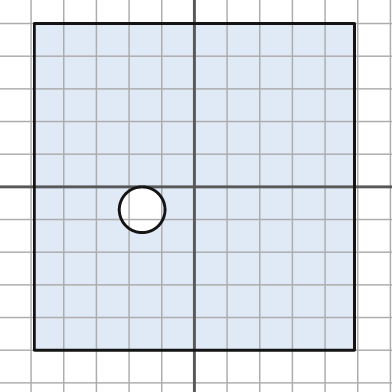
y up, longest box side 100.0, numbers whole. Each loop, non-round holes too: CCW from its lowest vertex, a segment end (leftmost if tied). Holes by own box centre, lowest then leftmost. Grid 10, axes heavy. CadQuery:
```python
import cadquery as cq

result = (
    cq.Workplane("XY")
    .moveTo(-49.0, -50.0)
    .lineTo(49.0, -50.0)
    .lineTo(49.0, 50.0)
    .lineTo(-49.0, 50.0)
    .close()
    .moveTo(-16.0, -7.0)
    .circle(7.0)
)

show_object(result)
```